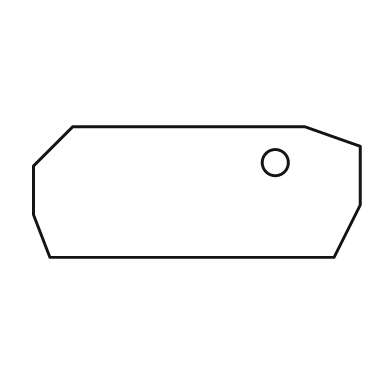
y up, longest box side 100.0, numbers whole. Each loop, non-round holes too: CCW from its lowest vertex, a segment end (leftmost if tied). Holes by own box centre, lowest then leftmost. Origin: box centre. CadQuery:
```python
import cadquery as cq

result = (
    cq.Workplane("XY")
    .moveTo(-45.0, -20.0)
    .lineTo(42.0, -20.0)
    .lineTo(50.0, -4.0)
    .lineTo(50.0, 14.0)
    .lineTo(33.0, 20.0)
    .lineTo(-38.0, 20.0)
    .lineTo(-50.0, 8.0)
    .lineTo(-50.0, -7.0)
    .close()
    .moveTo(24.0, 9.0)
    .circle(4.0)
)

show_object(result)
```